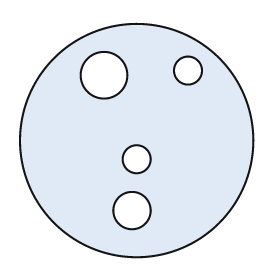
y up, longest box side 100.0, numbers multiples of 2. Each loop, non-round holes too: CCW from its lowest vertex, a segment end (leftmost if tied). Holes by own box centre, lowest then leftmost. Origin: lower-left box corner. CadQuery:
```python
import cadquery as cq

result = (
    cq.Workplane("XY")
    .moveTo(50.0, 50.0)
    .circle(50.0)
    .moveTo(48.0, 20.0)
    .circle(8.0)
    .moveTo(50.0, 42.0)
    .circle(6.0)
    .moveTo(36.0, 78.0)
    .circle(10.0)
    .moveTo(72.0, 80.0)
    .circle(6.0)
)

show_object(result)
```